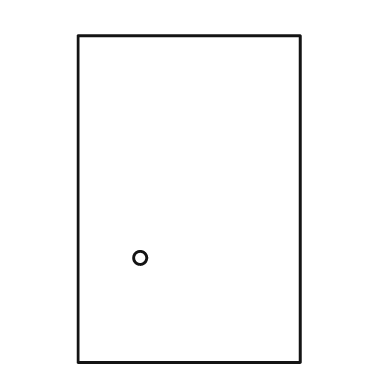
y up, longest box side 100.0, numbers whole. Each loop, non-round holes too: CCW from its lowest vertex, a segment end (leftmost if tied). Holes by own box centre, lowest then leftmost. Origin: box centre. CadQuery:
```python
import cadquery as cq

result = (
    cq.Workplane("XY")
    .moveTo(-34.0, -50.0)
    .lineTo(34.0, -50.0)
    .lineTo(34.0, 50.0)
    .lineTo(-34.0, 50.0)
    .close()
    .moveTo(-15.0, -18.0)
    .circle(2.0)
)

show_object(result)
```